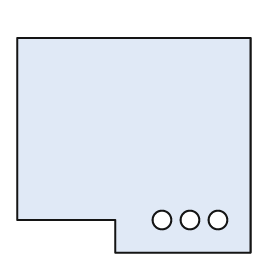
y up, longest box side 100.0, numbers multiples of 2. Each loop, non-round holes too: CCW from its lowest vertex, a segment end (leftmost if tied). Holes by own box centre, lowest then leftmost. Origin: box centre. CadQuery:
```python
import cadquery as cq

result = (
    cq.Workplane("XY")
    .moveTo(-8.0, -46.0)
    .lineTo(50.0, -46.0)
    .lineTo(50.0, 46.0)
    .lineTo(-50.0, 46.0)
    .lineTo(-50.0, -32.0)
    .lineTo(-8.0, -32.0)
    .close()
    .moveTo(12.0, -32.0)
    .circle(4.0)
    .moveTo(24.0, -32.0)
    .circle(4.0)
    .moveTo(36.0, -32.0)
    .circle(4.0)
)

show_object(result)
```